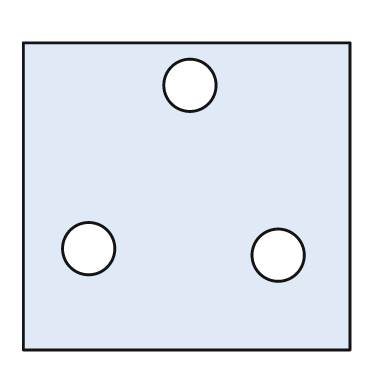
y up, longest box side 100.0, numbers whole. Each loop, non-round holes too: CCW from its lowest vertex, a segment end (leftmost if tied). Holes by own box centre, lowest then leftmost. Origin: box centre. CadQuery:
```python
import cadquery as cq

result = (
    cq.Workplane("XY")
    .moveTo(-50.0, -47.0)
    .lineTo(50.0, -47.0)
    .lineTo(50.0, 47.0)
    .lineTo(-50.0, 47.0)
    .close()
    .moveTo(28.0, -18.0)
    .circle(8.0)
    .moveTo(-30.0, -16.0)
    .circle(8.0)
    .moveTo(1.0, 34.0)
    .circle(8.0)
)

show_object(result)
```